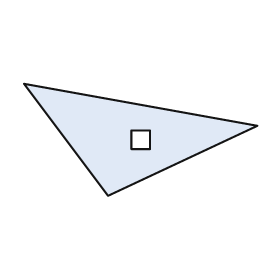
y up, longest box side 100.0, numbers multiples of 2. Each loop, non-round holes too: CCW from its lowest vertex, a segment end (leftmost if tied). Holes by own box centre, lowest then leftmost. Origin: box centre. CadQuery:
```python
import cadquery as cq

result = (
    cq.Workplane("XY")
    .moveTo(-14.0, -24.0)
    .lineTo(50.0, 6.0)
    .lineTo(-50.0, 24.0)
    .close()
    .moveTo(-4.0, -4.0)
    .lineTo(4.0, -4.0)
    .lineTo(4.0, 4.0)
    .lineTo(-4.0, 4.0)
    .close()
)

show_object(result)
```